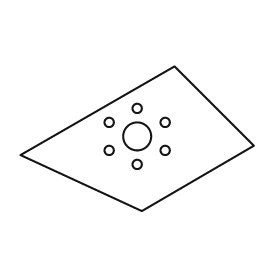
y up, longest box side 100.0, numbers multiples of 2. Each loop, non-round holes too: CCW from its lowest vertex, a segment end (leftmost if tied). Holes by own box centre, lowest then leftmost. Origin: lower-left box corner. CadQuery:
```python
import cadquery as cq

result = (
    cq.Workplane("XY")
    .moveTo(52.0, 0.0)
    .lineTo(100.0, 28.0)
    .lineTo(66.0, 62.0)
    .lineTo(0.0, 24.0)
    .close()
    .moveTo(50.0, 20.0)
    .circle(2.0)
    .moveTo(38.0, 26.0)
    .circle(2.0)
    .moveTo(62.0, 26.0)
    .circle(2.0)
    .moveTo(50.0, 32.0)
    .circle(6.0)
    .moveTo(38.0, 38.0)
    .circle(2.0)
    .moveTo(62.0, 38.0)
    .circle(2.0)
    .moveTo(50.0, 44.0)
    .circle(2.0)
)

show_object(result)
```